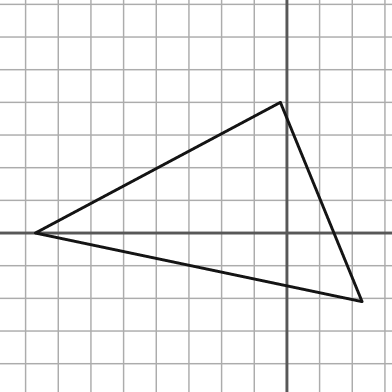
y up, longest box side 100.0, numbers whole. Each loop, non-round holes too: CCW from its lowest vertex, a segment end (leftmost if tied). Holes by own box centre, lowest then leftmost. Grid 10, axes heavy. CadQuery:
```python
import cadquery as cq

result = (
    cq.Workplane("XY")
    .moveTo(23.0, -21.0)
    .lineTo(-2.0, 40.0)
    .lineTo(-77.0, 0.0)
    .close()
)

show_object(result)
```